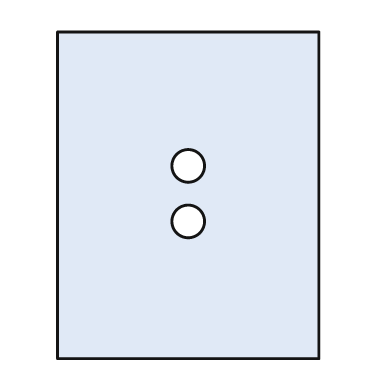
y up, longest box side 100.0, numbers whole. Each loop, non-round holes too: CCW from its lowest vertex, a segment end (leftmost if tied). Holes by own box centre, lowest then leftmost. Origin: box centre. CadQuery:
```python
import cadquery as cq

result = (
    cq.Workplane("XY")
    .moveTo(-40.0, -50.0)
    .lineTo(40.0, -50.0)
    .lineTo(40.0, 50.0)
    .lineTo(-40.0, 50.0)
    .close()
    .moveTo(0.0, -8.0)
    .circle(5.0)
    .moveTo(0.0, 9.0)
    .circle(5.0)
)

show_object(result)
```